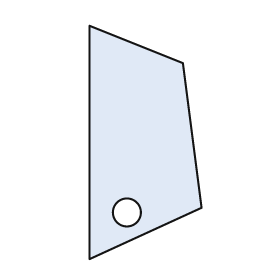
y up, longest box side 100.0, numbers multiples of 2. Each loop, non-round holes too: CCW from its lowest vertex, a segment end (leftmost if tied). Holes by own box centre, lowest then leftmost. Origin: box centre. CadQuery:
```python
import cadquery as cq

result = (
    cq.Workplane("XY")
    .moveTo(-24.0, -50.0)
    .lineTo(24.0, -28.0)
    .lineTo(16.0, 34.0)
    .lineTo(-24.0, 50.0)
    .close()
    .moveTo(-8.0, -30.0)
    .circle(6.0)
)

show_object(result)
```